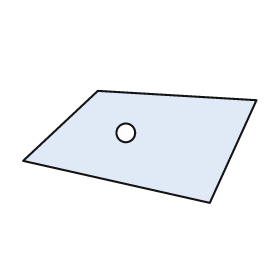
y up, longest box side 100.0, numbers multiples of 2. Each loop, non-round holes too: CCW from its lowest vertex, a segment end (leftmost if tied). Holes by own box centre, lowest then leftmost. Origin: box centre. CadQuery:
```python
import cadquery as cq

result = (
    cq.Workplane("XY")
    .moveTo(30.0, -24.0)
    .lineTo(50.0, 20.0)
    .lineTo(-18.0, 24.0)
    .lineTo(-50.0, -6.0)
    .close()
    .moveTo(-6.0, 6.0)
    .circle(4.0)
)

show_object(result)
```